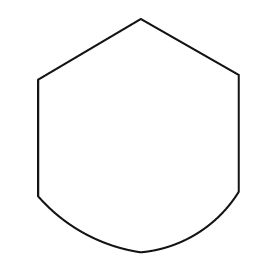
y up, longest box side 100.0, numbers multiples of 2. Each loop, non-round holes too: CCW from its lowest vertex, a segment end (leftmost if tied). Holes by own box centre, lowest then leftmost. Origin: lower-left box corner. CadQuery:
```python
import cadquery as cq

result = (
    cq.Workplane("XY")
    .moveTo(44.0, 0.0)
    .threePointArc((68.0, 8.0), (86.0, 26.0))
    .lineTo(86.0, 76.0)
    .lineTo(44.0, 100.0)
    .lineTo(0.0, 74.0)
    .lineTo(0.0, 24.0)
    .threePointArc((20.0, 8.0), (44.0, 0.0))
    .close()
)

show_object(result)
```